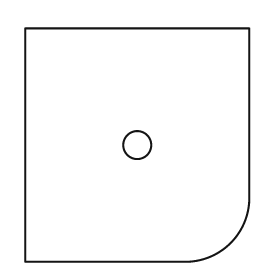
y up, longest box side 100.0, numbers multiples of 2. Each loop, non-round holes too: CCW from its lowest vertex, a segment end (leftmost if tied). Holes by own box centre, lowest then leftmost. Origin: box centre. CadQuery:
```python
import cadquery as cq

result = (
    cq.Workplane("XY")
    .moveTo(-48.0, -50.0)
    .lineTo(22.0, -50.0)
    .threePointArc((40.0, -42.0), (48.0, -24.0))
    .lineTo(48.0, 50.0)
    .lineTo(-48.0, 50.0)
    .close()
    .moveTo(0.0, 0.0)
    .circle(6.0)
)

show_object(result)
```